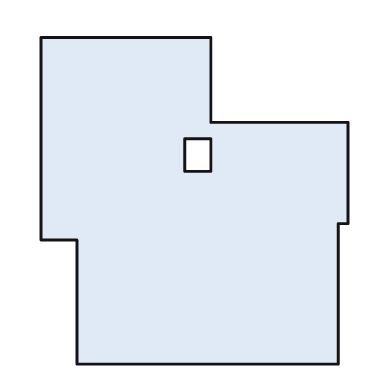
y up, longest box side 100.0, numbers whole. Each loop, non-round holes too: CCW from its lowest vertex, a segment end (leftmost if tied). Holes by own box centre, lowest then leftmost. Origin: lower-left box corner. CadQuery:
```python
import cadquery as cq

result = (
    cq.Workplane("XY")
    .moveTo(11.0, 0.0)
    .lineTo(91.0, 0.0)
    .lineTo(91.0, 43.0)
    .lineTo(94.0, 43.0)
    .lineTo(94.0, 74.0)
    .lineTo(52.0, 74.0)
    .lineTo(52.0, 100.0)
    .lineTo(0.0, 100.0)
    .lineTo(0.0, 38.0)
    .lineTo(11.0, 38.0)
    .close()
    .moveTo(44.0, 59.0)
    .lineTo(52.0, 59.0)
    .lineTo(52.0, 69.0)
    .lineTo(44.0, 69.0)
    .close()
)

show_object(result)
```